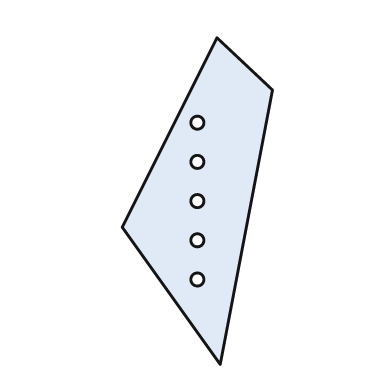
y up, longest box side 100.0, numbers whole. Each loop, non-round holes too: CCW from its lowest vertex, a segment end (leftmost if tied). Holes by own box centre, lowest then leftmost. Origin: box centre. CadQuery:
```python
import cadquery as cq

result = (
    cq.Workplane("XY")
    .moveTo(7.0, -50.0)
    .lineTo(23.0, 34.0)
    .lineTo(6.0, 50.0)
    .lineTo(-23.0, -8.0)
    .close()
    .moveTo(0.0, -24.0)
    .circle(2.0)
    .moveTo(0.0, -12.0)
    .circle(2.0)
    .moveTo(0.0, 0.0)
    .circle(2.0)
    .moveTo(0.0, 12.0)
    .circle(2.0)
    .moveTo(0.0, 24.0)
    .circle(2.0)
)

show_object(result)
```